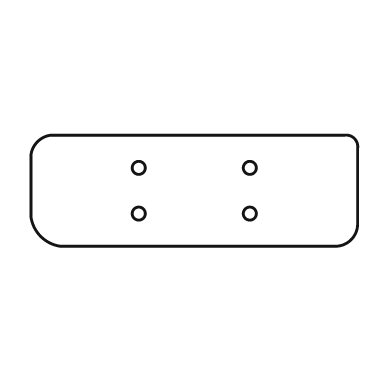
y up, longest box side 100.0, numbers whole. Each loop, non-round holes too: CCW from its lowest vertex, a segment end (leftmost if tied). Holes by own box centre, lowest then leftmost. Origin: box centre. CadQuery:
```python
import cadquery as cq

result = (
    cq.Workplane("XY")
    .moveTo(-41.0, -17.0)
    .lineTo(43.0, -17.0)
    .threePointArc((48.0, -15.0), (50.0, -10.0))
    .lineTo(50.0, 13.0)
    .threePointArc((49.0, 16.0), (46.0, 17.0))
    .lineTo(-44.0, 17.0)
    .threePointArc((-48.0, 15.0), (-50.0, 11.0))
    .lineTo(-50.0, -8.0)
    .threePointArc((-47.0, -14.0), (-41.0, -17.0))
    .close()
    .moveTo(-17.0, -7.0)
    .circle(2.0)
    .moveTo(17.0, -7.0)
    .circle(2.0)
    .moveTo(-17.0, 7.0)
    .circle(2.0)
    .moveTo(17.0, 7.0)
    .circle(2.0)
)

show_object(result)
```